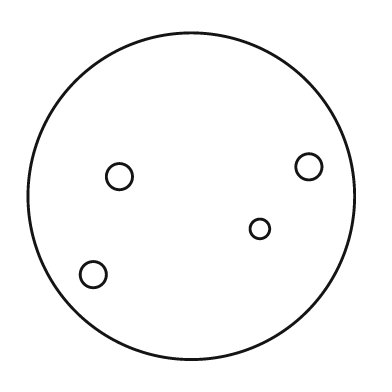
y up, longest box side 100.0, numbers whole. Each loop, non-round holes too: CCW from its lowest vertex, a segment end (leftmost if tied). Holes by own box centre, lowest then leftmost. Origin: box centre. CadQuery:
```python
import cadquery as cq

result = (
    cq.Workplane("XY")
    .moveTo(0.0, 0.0)
    .circle(50.0)
    .moveTo(-30.0, -24.0)
    .circle(4.0)
    .moveTo(21.0, -10.0)
    .circle(3.0)
    .moveTo(-22.0, 6.0)
    .circle(4.0)
    .moveTo(36.0, 9.0)
    .circle(4.0)
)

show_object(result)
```